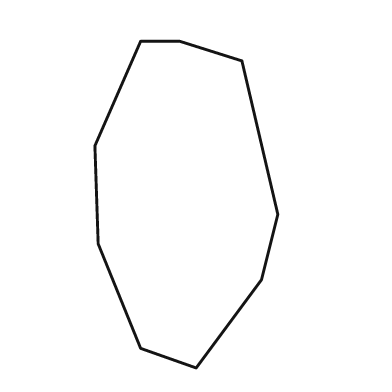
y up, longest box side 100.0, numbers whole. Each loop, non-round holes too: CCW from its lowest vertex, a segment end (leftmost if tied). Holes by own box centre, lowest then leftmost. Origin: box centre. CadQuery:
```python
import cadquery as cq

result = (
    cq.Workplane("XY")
    .moveTo(3.0, -50.0)
    .lineTo(23.0, -23.0)
    .lineTo(28.0, -3.0)
    .lineTo(17.0, 44.0)
    .lineTo(-2.0, 50.0)
    .lineTo(-14.0, 50.0)
    .lineTo(-28.0, 18.0)
    .lineTo(-27.0, -12.0)
    .lineTo(-14.0, -44.0)
    .close()
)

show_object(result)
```